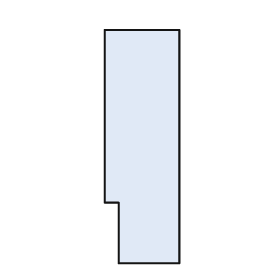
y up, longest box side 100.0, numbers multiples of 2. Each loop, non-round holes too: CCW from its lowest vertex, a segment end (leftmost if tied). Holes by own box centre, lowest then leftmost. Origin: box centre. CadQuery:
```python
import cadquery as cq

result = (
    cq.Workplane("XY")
    .moveTo(-10.0, -50.0)
    .lineTo(16.0, -50.0)
    .lineTo(16.0, 50.0)
    .lineTo(-16.0, 50.0)
    .lineTo(-16.0, -24.0)
    .lineTo(-10.0, -24.0)
    .close()
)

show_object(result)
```